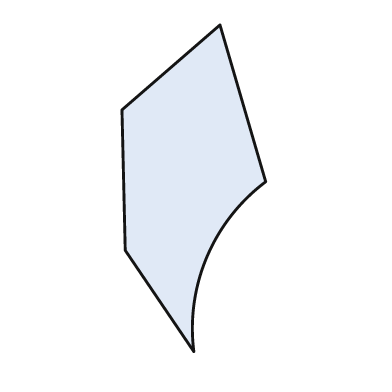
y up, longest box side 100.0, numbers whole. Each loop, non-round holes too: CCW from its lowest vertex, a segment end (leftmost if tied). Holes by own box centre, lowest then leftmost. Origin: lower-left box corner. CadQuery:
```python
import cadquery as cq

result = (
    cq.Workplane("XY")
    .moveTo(22.0, 0.0)
    .threePointArc((26.0, 29.0), (44.0, 52.0))
    .lineTo(30.0, 100.0)
    .lineTo(0.0, 74.0)
    .lineTo(1.0, 31.0)
    .close()
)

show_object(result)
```